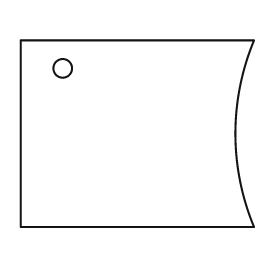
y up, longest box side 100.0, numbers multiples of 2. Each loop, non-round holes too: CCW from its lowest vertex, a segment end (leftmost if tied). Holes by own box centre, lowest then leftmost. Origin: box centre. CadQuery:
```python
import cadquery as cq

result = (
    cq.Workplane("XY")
    .moveTo(-50.0, -40.0)
    .lineTo(50.0, -40.0)
    .threePointArc((42.0, 0.0), (50.0, 40.0))
    .lineTo(-50.0, 40.0)
    .close()
    .moveTo(-32.0, 28.0)
    .circle(4.0)
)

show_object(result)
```